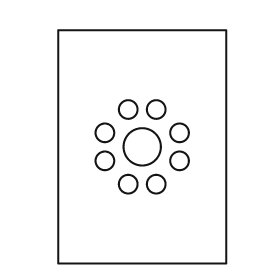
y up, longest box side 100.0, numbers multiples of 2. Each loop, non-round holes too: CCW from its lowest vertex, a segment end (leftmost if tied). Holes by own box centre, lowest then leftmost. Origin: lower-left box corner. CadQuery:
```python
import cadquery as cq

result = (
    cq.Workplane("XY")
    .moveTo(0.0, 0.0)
    .lineTo(72.0, 0.0)
    .lineTo(72.0, 100.0)
    .lineTo(0.0, 100.0)
    .close()
    .moveTo(30.0, 34.0)
    .circle(4.0)
    .moveTo(42.0, 34.0)
    .circle(4.0)
    .moveTo(20.0, 44.0)
    .circle(4.0)
    .moveTo(52.0, 44.0)
    .circle(4.0)
    .moveTo(36.0, 50.0)
    .circle(8.0)
    .moveTo(20.0, 56.0)
    .circle(4.0)
    .moveTo(52.0, 56.0)
    .circle(4.0)
    .moveTo(30.0, 66.0)
    .circle(4.0)
    .moveTo(42.0, 66.0)
    .circle(4.0)
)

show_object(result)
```